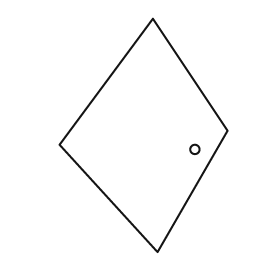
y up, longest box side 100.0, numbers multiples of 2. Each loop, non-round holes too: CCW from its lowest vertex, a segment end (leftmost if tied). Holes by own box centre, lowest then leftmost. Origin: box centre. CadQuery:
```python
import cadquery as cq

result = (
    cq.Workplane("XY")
    .moveTo(6.0, -50.0)
    .lineTo(36.0, 2.0)
    .lineTo(4.0, 50.0)
    .lineTo(-36.0, -4.0)
    .close()
    .moveTo(22.0, -6.0)
    .circle(2.0)
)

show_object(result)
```